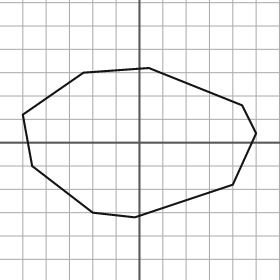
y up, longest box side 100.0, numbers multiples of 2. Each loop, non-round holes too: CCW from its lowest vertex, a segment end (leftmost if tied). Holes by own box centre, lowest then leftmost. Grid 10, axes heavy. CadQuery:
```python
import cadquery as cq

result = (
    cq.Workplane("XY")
    .moveTo(-2.0, -32.0)
    .lineTo(40.0, -18.0)
    .lineTo(50.0, 4.0)
    .lineTo(44.0, 16.0)
    .lineTo(4.0, 32.0)
    .lineTo(-24.0, 30.0)
    .lineTo(-50.0, 12.0)
    .lineTo(-46.0, -10.0)
    .lineTo(-20.0, -30.0)
    .close()
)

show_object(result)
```